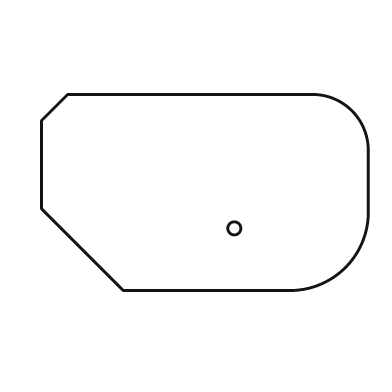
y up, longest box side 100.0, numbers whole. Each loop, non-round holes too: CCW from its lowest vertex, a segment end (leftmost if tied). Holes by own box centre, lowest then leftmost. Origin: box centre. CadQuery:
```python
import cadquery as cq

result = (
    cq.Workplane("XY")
    .moveTo(-25.0, -30.0)
    .lineTo(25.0, -30.0)
    .threePointArc((43.0, -23.0), (50.0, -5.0))
    .lineTo(50.0, 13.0)
    .threePointArc((45.0, 25.0), (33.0, 30.0))
    .lineTo(-42.0, 30.0)
    .lineTo(-50.0, 22.0)
    .lineTo(-50.0, -5.0)
    .close()
    .moveTo(9.0, -11.0)
    .circle(2.0)
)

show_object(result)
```